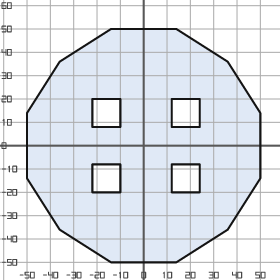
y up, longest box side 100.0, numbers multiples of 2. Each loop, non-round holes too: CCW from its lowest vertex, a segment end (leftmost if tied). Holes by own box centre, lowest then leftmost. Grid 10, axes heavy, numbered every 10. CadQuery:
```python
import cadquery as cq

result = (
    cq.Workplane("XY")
    .moveTo(-14.0, -50.0)
    .lineTo(14.0, -50.0)
    .lineTo(36.0, -36.0)
    .lineTo(50.0, -14.0)
    .lineTo(50.0, 14.0)
    .lineTo(36.0, 36.0)
    .lineTo(14.0, 50.0)
    .lineTo(-14.0, 50.0)
    .lineTo(-36.0, 36.0)
    .lineTo(-50.0, 14.0)
    .lineTo(-50.0, -14.0)
    .lineTo(-36.0, -36.0)
    .close()
    .moveTo(-22.0, -20.0)
    .lineTo(-10.0, -20.0)
    .lineTo(-10.0, -8.0)
    .lineTo(-22.0, -8.0)
    .close()
    .moveTo(12.0, -20.0)
    .lineTo(24.0, -20.0)
    .lineTo(24.0, -8.0)
    .lineTo(12.0, -8.0)
    .close()
    .moveTo(-22.0, 8.0)
    .lineTo(-10.0, 8.0)
    .lineTo(-10.0, 20.0)
    .lineTo(-22.0, 20.0)
    .close()
    .moveTo(12.0, 8.0)
    .lineTo(24.0, 8.0)
    .lineTo(24.0, 20.0)
    .lineTo(12.0, 20.0)
    .close()
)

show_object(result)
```